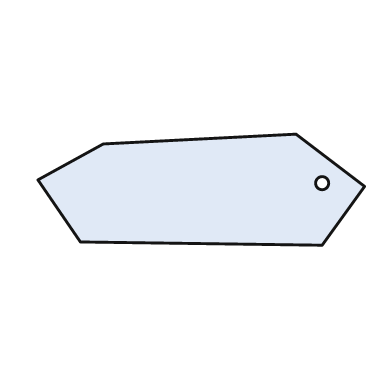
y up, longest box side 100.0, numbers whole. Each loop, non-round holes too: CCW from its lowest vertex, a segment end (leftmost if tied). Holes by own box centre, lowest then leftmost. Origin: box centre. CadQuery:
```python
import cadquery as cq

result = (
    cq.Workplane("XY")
    .moveTo(37.0, -17.0)
    .lineTo(50.0, 1.0)
    .lineTo(29.0, 17.0)
    .lineTo(-30.0, 14.0)
    .lineTo(-50.0, 3.0)
    .lineTo(-37.0, -16.0)
    .close()
    .moveTo(37.0, 2.0)
    .circle(2.0)
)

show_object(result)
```